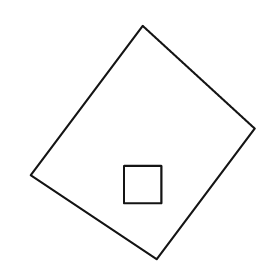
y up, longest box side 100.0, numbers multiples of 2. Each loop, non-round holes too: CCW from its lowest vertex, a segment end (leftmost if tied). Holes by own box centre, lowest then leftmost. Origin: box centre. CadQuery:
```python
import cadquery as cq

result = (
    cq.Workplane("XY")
    .moveTo(6.0, -50.0)
    .lineTo(48.0, 6.0)
    .lineTo(0.0, 50.0)
    .lineTo(-48.0, -14.0)
    .close()
    .moveTo(-8.0, -26.0)
    .lineTo(8.0, -26.0)
    .lineTo(8.0, -10.0)
    .lineTo(-8.0, -10.0)
    .close()
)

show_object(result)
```